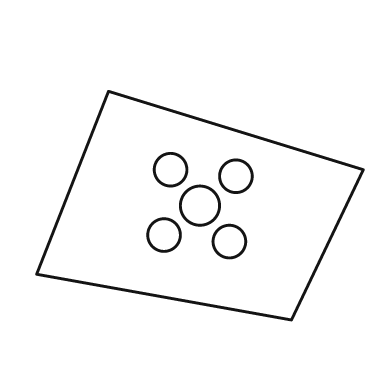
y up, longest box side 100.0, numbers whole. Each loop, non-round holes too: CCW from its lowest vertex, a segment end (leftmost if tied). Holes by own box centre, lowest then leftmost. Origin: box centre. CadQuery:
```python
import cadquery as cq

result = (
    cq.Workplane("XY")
    .moveTo(28.0, -35.0)
    .lineTo(50.0, 11.0)
    .lineTo(-28.0, 35.0)
    .lineTo(-50.0, -21.0)
    .close()
    .moveTo(9.0, -11.0)
    .circle(5.0)
    .moveTo(-11.0, -9.0)
    .circle(5.0)
    .moveTo(0.0, 0.0)
    .circle(6.0)
    .moveTo(11.0, 9.0)
    .circle(5.0)
    .moveTo(-9.0, 11.0)
    .circle(5.0)
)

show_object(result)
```